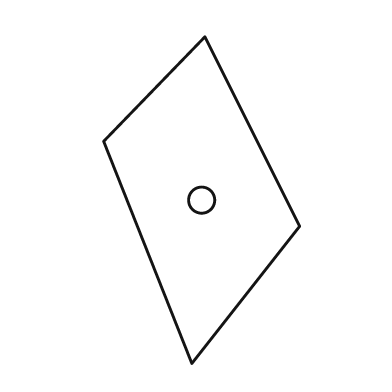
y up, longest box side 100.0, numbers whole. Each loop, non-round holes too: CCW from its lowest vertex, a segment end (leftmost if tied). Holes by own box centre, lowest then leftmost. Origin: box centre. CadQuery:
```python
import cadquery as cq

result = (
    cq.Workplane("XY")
    .moveTo(-3.0, -50.0)
    .lineTo(30.0, -8.0)
    .lineTo(1.0, 50.0)
    .lineTo(-30.0, 18.0)
    .close()
    .moveTo(0.0, 0.0)
    .circle(4.0)
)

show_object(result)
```